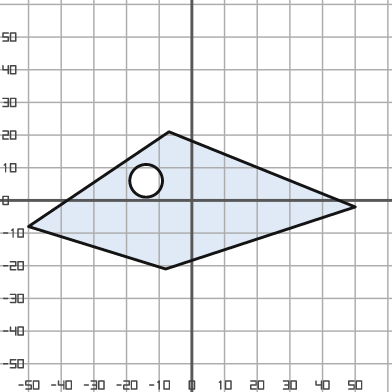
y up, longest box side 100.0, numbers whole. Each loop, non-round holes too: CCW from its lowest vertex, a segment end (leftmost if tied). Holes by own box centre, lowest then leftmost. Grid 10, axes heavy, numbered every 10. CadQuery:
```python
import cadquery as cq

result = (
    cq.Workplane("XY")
    .moveTo(-8.0, -21.0)
    .lineTo(50.0, -2.0)
    .lineTo(-7.0, 21.0)
    .lineTo(-50.0, -8.0)
    .close()
    .moveTo(-14.0, 6.0)
    .circle(5.0)
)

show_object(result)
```